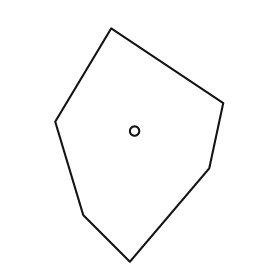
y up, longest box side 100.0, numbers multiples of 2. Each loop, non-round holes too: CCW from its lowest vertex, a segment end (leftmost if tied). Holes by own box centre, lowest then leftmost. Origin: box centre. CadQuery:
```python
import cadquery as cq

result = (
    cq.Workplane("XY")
    .moveTo(-4.0, -50.0)
    .lineTo(30.0, -10.0)
    .lineTo(36.0, 18.0)
    .lineTo(-12.0, 50.0)
    .lineTo(-36.0, 10.0)
    .lineTo(-24.0, -30.0)
    .close()
    .moveTo(-2.0, 6.0)
    .circle(2.0)
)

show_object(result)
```